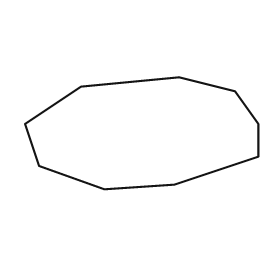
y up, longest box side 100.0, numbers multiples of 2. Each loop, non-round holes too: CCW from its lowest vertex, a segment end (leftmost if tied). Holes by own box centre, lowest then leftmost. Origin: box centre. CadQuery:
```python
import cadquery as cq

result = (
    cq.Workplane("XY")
    .moveTo(-16.0, -24.0)
    .lineTo(14.0, -22.0)
    .lineTo(50.0, -10.0)
    .lineTo(50.0, 4.0)
    .lineTo(40.0, 18.0)
    .lineTo(16.0, 24.0)
    .lineTo(-26.0, 20.0)
    .lineTo(-50.0, 4.0)
    .lineTo(-44.0, -14.0)
    .close()
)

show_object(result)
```